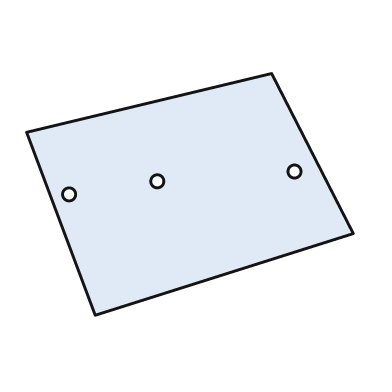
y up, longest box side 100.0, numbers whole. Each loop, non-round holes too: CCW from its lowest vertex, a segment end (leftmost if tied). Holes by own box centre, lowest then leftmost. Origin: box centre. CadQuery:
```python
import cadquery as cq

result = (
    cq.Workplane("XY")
    .moveTo(-29.0, -37.0)
    .lineTo(50.0, -12.0)
    .lineTo(25.0, 37.0)
    .lineTo(-50.0, 19.0)
    .close()
    .moveTo(-37.0, 0.0)
    .circle(2.0)
    .moveTo(-10.0, 4.0)
    .circle(2.0)
    .moveTo(32.0, 7.0)
    .circle(2.0)
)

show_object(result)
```